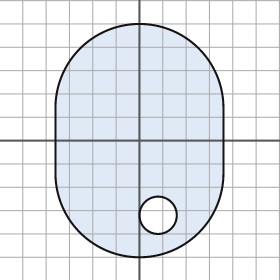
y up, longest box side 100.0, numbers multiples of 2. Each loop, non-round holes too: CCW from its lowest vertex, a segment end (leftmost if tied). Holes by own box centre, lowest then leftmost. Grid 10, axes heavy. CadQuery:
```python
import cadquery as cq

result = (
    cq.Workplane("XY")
    .moveTo(-36.0, -14.0)
    .threePointArc((0.0, -50.0), (36.0, -14.0))
    .lineTo(36.0, 14.0)
    .threePointArc((0.0, 50.0), (-36.0, 14.0))
    .close()
    .moveTo(8.0, -32.0)
    .circle(8.0)
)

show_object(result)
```